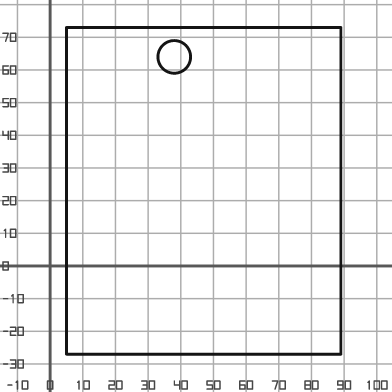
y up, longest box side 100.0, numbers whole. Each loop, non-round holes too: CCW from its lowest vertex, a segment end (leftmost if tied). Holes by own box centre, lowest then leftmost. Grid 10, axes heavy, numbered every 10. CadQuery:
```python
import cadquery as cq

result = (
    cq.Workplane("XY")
    .moveTo(5.0, -27.0)
    .lineTo(89.0, -27.0)
    .lineTo(89.0, 73.0)
    .lineTo(5.0, 73.0)
    .close()
    .moveTo(38.0, 64.0)
    .circle(5.0)
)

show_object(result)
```